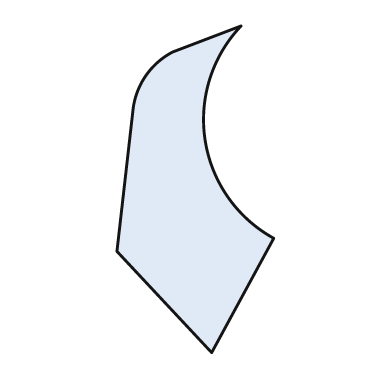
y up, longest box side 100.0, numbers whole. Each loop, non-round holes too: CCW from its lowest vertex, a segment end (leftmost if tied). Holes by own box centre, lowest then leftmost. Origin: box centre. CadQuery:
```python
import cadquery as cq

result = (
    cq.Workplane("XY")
    .moveTo(5.0, -50.0)
    .lineTo(24.0, -15.0)
    .threePointArc((3.0, 15.0), (14.0, 50.0))
    .lineTo(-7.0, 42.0)
    .threePointArc((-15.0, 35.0), (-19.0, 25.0))
    .lineTo(-24.0, -19.0)
    .close()
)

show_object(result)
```